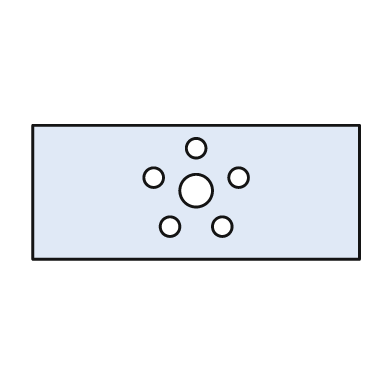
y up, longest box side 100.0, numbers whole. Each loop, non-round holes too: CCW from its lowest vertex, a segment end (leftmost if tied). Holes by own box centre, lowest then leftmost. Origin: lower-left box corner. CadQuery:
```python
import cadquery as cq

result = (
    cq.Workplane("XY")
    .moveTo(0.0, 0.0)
    .lineTo(100.0, 0.0)
    .lineTo(100.0, 41.0)
    .lineTo(0.0, 41.0)
    .close()
    .moveTo(42.0, 10.0)
    .circle(3.0)
    .moveTo(58.0, 10.0)
    .circle(3.0)
    .moveTo(50.0, 21.0)
    .circle(5.0)
    .moveTo(37.0, 25.0)
    .circle(3.0)
    .moveTo(63.0, 25.0)
    .circle(3.0)
    .moveTo(50.0, 34.0)
    .circle(3.0)
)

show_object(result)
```